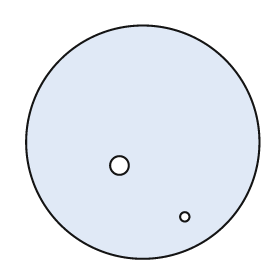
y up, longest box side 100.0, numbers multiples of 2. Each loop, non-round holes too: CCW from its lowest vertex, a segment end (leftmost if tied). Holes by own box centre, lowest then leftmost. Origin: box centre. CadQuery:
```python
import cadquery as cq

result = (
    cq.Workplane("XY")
    .moveTo(0.0, 0.0)
    .circle(50.0)
    .moveTo(18.0, -32.0)
    .circle(2.0)
    .moveTo(-10.0, -10.0)
    .circle(4.0)
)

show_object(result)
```